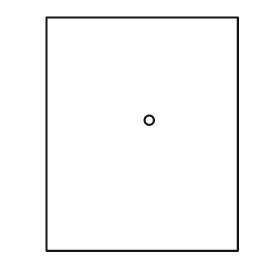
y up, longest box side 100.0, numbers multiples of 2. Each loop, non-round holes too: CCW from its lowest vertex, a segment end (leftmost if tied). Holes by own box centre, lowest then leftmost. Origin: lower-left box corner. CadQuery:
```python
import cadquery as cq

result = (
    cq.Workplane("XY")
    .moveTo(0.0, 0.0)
    .lineTo(82.0, 0.0)
    .lineTo(82.0, 100.0)
    .lineTo(0.0, 100.0)
    .close()
    .moveTo(44.0, 56.0)
    .circle(2.0)
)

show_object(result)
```